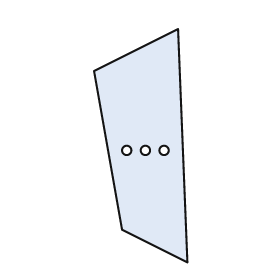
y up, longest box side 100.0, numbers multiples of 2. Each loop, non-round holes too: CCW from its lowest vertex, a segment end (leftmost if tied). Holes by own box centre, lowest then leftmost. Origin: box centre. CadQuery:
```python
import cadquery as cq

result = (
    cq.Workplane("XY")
    .moveTo(20.0, -50.0)
    .lineTo(16.0, 50.0)
    .lineTo(-20.0, 32.0)
    .lineTo(-8.0, -36.0)
    .close()
    .moveTo(-6.0, -2.0)
    .circle(2.0)
    .moveTo(2.0, -2.0)
    .circle(2.0)
    .moveTo(10.0, -2.0)
    .circle(2.0)
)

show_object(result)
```